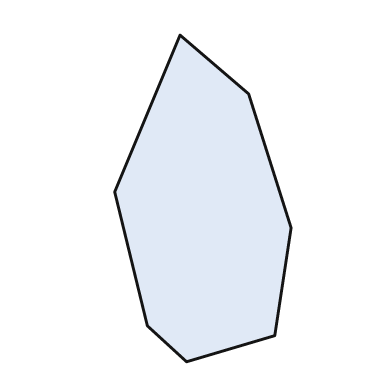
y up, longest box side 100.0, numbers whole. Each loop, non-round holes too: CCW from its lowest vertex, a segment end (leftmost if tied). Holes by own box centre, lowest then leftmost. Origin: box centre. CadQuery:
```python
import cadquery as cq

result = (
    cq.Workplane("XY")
    .moveTo(-5.0, -50.0)
    .lineTo(22.0, -42.0)
    .lineTo(27.0, -9.0)
    .lineTo(14.0, 32.0)
    .lineTo(-7.0, 50.0)
    .lineTo(-27.0, 2.0)
    .lineTo(-17.0, -39.0)
    .close()
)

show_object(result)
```